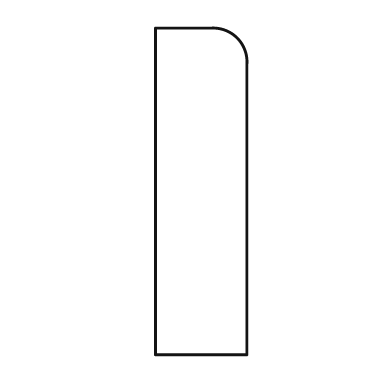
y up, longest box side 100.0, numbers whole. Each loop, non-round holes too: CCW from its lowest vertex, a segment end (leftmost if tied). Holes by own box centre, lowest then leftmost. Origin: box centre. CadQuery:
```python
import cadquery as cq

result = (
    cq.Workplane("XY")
    .moveTo(-14.0, -50.0)
    .lineTo(14.0, -50.0)
    .lineTo(14.0, 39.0)
    .threePointArc((11.0, 47.0), (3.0, 50.0))
    .lineTo(-14.0, 50.0)
    .close()
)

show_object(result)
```